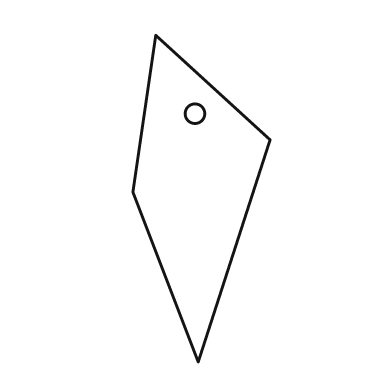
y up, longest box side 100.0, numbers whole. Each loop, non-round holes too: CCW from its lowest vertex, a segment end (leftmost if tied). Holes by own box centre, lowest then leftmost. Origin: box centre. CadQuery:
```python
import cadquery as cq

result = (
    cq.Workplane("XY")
    .moveTo(-1.0, -50.0)
    .lineTo(21.0, 18.0)
    .lineTo(-14.0, 50.0)
    .lineTo(-21.0, 2.0)
    .close()
    .moveTo(-2.0, 26.0)
    .circle(3.0)
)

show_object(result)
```